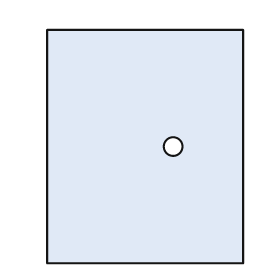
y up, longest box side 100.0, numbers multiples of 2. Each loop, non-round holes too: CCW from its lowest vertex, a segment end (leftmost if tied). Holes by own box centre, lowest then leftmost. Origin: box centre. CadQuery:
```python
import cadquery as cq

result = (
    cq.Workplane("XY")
    .moveTo(-42.0, -50.0)
    .lineTo(42.0, -50.0)
    .lineTo(42.0, 50.0)
    .lineTo(-42.0, 50.0)
    .close()
    .moveTo(12.0, 0.0)
    .circle(4.0)
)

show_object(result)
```